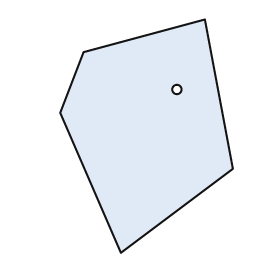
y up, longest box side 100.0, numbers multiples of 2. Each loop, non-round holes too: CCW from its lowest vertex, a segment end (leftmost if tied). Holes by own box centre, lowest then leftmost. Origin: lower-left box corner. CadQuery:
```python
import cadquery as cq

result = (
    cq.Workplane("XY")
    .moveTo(26.0, 0.0)
    .lineTo(74.0, 36.0)
    .lineTo(62.0, 100.0)
    .lineTo(10.0, 86.0)
    .lineTo(0.0, 60.0)
    .close()
    .moveTo(50.0, 70.0)
    .circle(2.0)
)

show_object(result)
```